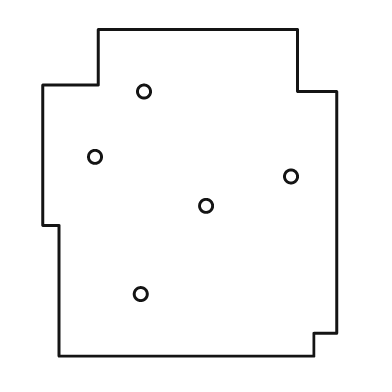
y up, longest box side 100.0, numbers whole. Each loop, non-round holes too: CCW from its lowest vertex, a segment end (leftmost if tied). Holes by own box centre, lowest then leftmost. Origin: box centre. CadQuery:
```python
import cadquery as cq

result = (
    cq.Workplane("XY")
    .moveTo(-40.0, -50.0)
    .lineTo(38.0, -50.0)
    .lineTo(38.0, -43.0)
    .lineTo(45.0, -43.0)
    .lineTo(45.0, 31.0)
    .lineTo(33.0, 31.0)
    .lineTo(33.0, 50.0)
    .lineTo(-28.0, 50.0)
    .lineTo(-28.0, 33.0)
    .lineTo(-45.0, 33.0)
    .lineTo(-45.0, -10.0)
    .lineTo(-40.0, -10.0)
    .close()
    .moveTo(-15.0, -31.0)
    .circle(2.0)
    .moveTo(5.0, -4.0)
    .circle(2.0)
    .moveTo(31.0, 5.0)
    .circle(2.0)
    .moveTo(-29.0, 11.0)
    .circle(2.0)
    .moveTo(-14.0, 31.0)
    .circle(2.0)
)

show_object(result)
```